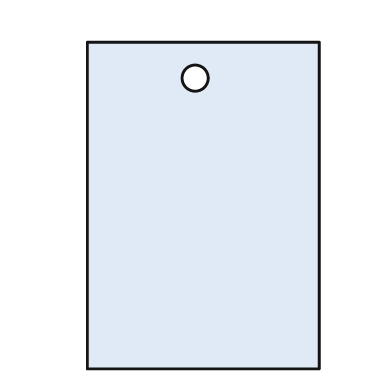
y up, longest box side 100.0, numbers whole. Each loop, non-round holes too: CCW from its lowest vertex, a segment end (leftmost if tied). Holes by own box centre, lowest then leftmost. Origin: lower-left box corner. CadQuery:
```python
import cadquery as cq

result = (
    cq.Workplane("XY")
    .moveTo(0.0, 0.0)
    .lineTo(71.0, 0.0)
    .lineTo(71.0, 100.0)
    .lineTo(0.0, 100.0)
    .close()
    .moveTo(33.0, 89.0)
    .circle(4.0)
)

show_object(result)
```